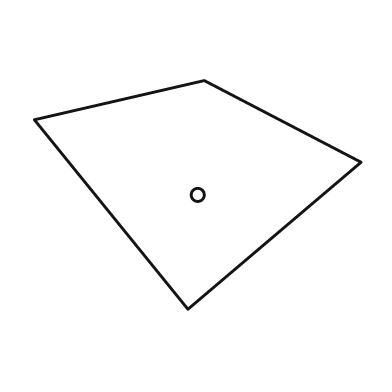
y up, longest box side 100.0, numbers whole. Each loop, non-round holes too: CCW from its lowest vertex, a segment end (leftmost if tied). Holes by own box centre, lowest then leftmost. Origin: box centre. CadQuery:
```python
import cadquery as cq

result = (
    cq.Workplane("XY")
    .moveTo(-3.0, -35.0)
    .lineTo(50.0, 10.0)
    .lineTo(2.0, 35.0)
    .lineTo(-50.0, 23.0)
    .close()
    .moveTo(0.0, 0.0)
    .circle(2.0)
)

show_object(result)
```